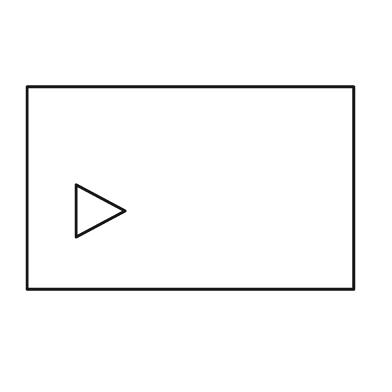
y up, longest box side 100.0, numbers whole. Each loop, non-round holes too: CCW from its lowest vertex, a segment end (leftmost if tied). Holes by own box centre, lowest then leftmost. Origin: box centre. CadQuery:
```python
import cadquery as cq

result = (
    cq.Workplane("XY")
    .moveTo(-50.0, -31.0)
    .lineTo(50.0, -31.0)
    .lineTo(50.0, 31.0)
    .lineTo(-50.0, 31.0)
    .close()
    .moveTo(-35.0, -15.0)
    .lineTo(-20.0, -7.0)
    .lineTo(-35.0, 1.0)
    .close()
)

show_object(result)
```